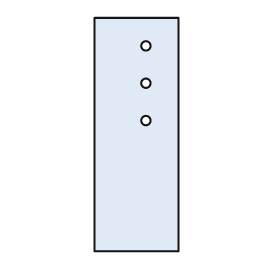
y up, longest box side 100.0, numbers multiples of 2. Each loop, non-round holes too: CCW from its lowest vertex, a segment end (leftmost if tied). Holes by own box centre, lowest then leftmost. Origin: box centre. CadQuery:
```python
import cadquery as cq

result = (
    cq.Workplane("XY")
    .moveTo(-18.0, -50.0)
    .lineTo(18.0, -50.0)
    .lineTo(18.0, 50.0)
    .lineTo(-18.0, 50.0)
    .close()
    .moveTo(4.0, 6.0)
    .circle(2.0)
    .moveTo(4.0, 22.0)
    .circle(2.0)
    .moveTo(4.0, 38.0)
    .circle(2.0)
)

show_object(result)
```